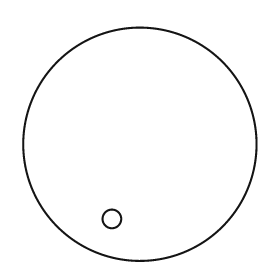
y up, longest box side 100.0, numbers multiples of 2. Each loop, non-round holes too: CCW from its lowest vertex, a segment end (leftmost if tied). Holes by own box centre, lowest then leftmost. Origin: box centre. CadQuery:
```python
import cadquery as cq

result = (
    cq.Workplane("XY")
    .moveTo(0.0, 0.0)
    .circle(50.0)
    .moveTo(-12.0, -32.0)
    .circle(4.0)
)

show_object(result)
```